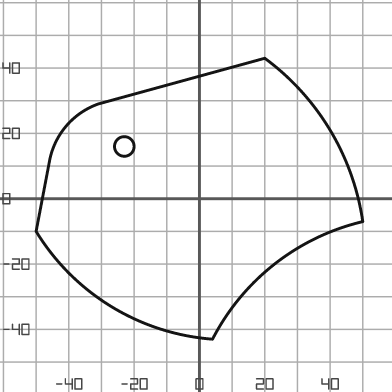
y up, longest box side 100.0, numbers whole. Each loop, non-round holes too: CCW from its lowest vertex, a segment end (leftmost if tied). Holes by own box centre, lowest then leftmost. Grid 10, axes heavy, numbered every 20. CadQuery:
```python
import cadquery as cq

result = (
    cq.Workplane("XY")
    .moveTo(4.0, -43.0)
    .threePointArc((23.0, -20.0), (50.0, -7.0))
    .threePointArc((40.0, 21.0), (20.0, 43.0))
    .lineTo(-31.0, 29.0)
    .threePointArc((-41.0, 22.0), (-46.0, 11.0))
    .lineTo(-50.0, -10.0)
    .threePointArc((-27.0, -33.0), (4.0, -43.0))
    .close()
    .moveTo(-23.0, 16.0)
    .circle(3.0)
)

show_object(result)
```